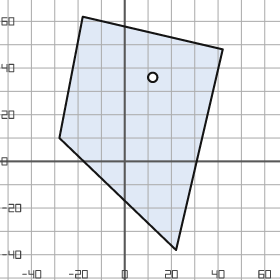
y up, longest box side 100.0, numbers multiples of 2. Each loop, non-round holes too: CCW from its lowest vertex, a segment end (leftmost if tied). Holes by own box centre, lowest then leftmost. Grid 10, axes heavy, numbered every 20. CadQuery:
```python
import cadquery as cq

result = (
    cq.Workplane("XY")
    .moveTo(22.0, -38.0)
    .lineTo(42.0, 48.0)
    .lineTo(-18.0, 62.0)
    .lineTo(-28.0, 10.0)
    .close()
    .moveTo(12.0, 36.0)
    .circle(2.0)
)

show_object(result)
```